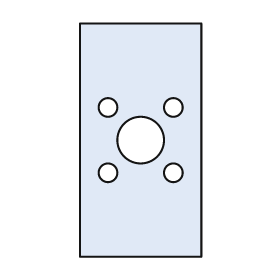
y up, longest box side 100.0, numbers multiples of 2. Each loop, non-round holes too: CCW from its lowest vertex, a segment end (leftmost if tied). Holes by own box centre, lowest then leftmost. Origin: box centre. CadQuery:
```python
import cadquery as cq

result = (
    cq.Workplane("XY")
    .moveTo(-26.0, -50.0)
    .lineTo(26.0, -50.0)
    .lineTo(26.0, 50.0)
    .lineTo(-26.0, 50.0)
    .close()
    .moveTo(-14.0, -14.0)
    .circle(4.0)
    .moveTo(14.0, -14.0)
    .circle(4.0)
    .moveTo(0.0, 0.0)
    .circle(10.0)
    .moveTo(-14.0, 14.0)
    .circle(4.0)
    .moveTo(14.0, 14.0)
    .circle(4.0)
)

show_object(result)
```